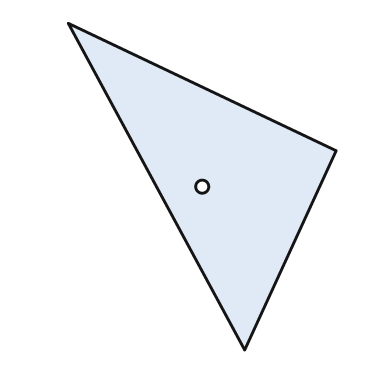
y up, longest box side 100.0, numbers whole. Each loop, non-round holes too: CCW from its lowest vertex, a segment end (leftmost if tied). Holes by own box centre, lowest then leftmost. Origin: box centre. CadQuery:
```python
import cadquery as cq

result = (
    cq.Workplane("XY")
    .moveTo(13.0, -50.0)
    .lineTo(41.0, 11.0)
    .lineTo(-41.0, 50.0)
    .close()
    .moveTo(0.0, 0.0)
    .circle(2.0)
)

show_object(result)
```